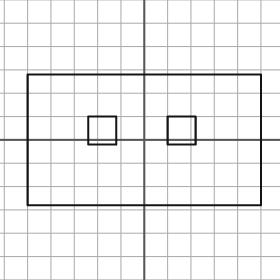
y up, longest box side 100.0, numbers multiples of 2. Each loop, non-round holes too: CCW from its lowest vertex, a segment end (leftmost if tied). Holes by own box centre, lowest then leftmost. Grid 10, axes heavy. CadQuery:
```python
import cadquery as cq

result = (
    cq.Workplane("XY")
    .moveTo(-50.0, -28.0)
    .lineTo(50.0, -28.0)
    .lineTo(50.0, 28.0)
    .lineTo(-50.0, 28.0)
    .close()
    .moveTo(-24.0, -2.0)
    .lineTo(-12.0, -2.0)
    .lineTo(-12.0, 10.0)
    .lineTo(-24.0, 10.0)
    .close()
    .moveTo(10.0, -2.0)
    .lineTo(22.0, -2.0)
    .lineTo(22.0, 10.0)
    .lineTo(10.0, 10.0)
    .close()
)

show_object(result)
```